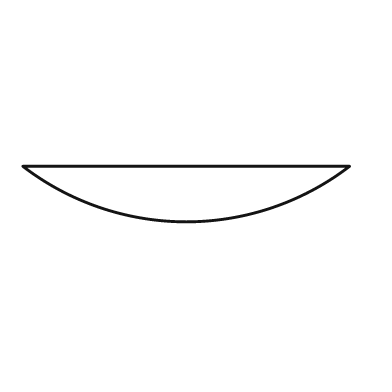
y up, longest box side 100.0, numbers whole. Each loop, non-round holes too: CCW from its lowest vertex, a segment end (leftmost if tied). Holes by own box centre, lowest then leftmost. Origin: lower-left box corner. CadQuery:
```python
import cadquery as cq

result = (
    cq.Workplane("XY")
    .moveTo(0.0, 17.0)
    .threePointArc((50.0, 0.0), (100.0, 17.0))
    .close()
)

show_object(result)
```